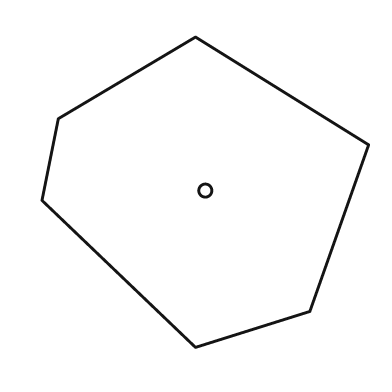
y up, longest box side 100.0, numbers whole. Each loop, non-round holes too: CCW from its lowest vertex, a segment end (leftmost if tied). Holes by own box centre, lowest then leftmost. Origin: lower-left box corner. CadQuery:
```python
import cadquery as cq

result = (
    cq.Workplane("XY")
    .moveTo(47.0, 0.0)
    .lineTo(82.0, 11.0)
    .lineTo(100.0, 62.0)
    .lineTo(47.0, 95.0)
    .lineTo(5.0, 70.0)
    .lineTo(0.0, 45.0)
    .close()
    .moveTo(50.0, 48.0)
    .circle(2.0)
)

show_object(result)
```